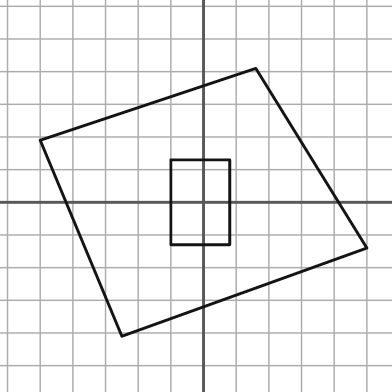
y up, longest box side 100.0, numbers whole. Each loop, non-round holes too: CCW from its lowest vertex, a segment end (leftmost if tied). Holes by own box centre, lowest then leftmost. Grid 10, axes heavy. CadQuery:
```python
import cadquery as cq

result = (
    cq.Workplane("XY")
    .moveTo(-25.0, -41.0)
    .lineTo(50.0, -14.0)
    .lineTo(16.0, 41.0)
    .lineTo(-50.0, 19.0)
    .close()
    .moveTo(-10.0, -13.0)
    .lineTo(8.0, -13.0)
    .lineTo(8.0, 13.0)
    .lineTo(-10.0, 13.0)
    .close()
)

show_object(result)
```